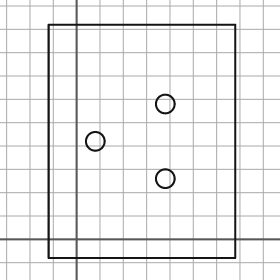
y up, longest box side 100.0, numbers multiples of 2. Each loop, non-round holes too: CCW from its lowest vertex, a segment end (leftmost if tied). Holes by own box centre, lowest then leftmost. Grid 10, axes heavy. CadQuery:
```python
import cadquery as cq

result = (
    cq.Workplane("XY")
    .moveTo(-12.0, -8.0)
    .lineTo(68.0, -8.0)
    .lineTo(68.0, 92.0)
    .lineTo(-12.0, 92.0)
    .close()
    .moveTo(38.0, 26.0)
    .circle(4.0)
    .moveTo(8.0, 42.0)
    .circle(4.0)
    .moveTo(38.0, 58.0)
    .circle(4.0)
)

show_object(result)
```